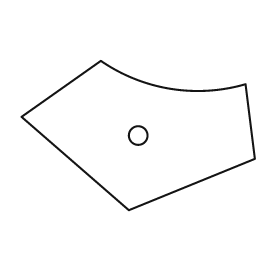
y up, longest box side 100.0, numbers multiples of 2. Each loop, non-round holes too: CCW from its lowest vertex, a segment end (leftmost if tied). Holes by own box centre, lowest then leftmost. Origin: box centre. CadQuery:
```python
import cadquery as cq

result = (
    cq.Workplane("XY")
    .moveTo(-4.0, -32.0)
    .lineTo(50.0, -10.0)
    .lineTo(46.0, 22.0)
    .threePointArc((14.0, 20.0), (-16.0, 32.0))
    .lineTo(-50.0, 8.0)
    .close()
    .moveTo(0.0, 0.0)
    .circle(4.0)
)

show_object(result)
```